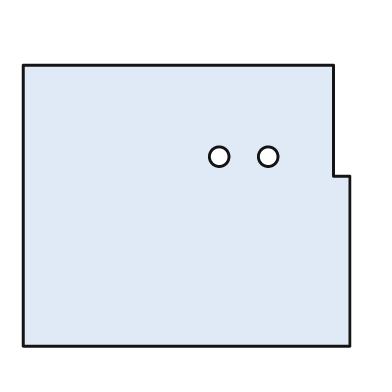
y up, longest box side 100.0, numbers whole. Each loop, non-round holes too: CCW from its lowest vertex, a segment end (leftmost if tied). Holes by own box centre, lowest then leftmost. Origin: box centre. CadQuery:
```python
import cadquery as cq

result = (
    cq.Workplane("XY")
    .moveTo(-50.0, -43.0)
    .lineTo(50.0, -43.0)
    .lineTo(50.0, 9.0)
    .lineTo(45.0, 9.0)
    .lineTo(45.0, 43.0)
    .lineTo(-50.0, 43.0)
    .close()
    .moveTo(10.0, 15.0)
    .circle(3.0)
    .moveTo(25.0, 15.0)
    .circle(3.0)
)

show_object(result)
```